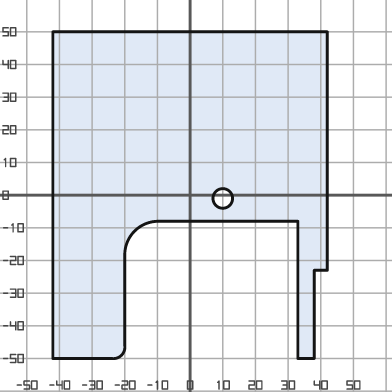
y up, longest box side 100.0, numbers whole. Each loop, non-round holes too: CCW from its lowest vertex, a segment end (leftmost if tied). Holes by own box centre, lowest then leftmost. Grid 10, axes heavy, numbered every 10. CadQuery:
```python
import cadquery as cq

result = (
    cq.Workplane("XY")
    .moveTo(-42.0, -50.0)
    .lineTo(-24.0, -50.0)
    .threePointArc((-21.0, -49.0), (-20.0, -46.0))
    .lineTo(-20.0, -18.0)
    .threePointArc((-17.0, -11.0), (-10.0, -8.0))
    .lineTo(33.0, -8.0)
    .lineTo(33.0, -50.0)
    .lineTo(38.0, -50.0)
    .lineTo(38.0, -23.0)
    .lineTo(42.0, -23.0)
    .lineTo(42.0, 50.0)
    .lineTo(-42.0, 50.0)
    .close()
    .moveTo(10.0, -1.0)
    .circle(3.0)
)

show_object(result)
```